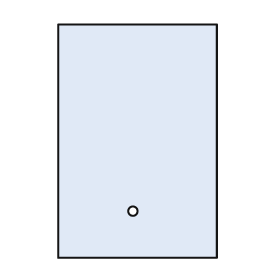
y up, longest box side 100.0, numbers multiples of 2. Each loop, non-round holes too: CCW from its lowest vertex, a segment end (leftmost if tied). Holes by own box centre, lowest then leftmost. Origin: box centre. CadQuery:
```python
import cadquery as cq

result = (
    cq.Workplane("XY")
    .moveTo(-34.0, -50.0)
    .lineTo(34.0, -50.0)
    .lineTo(34.0, 50.0)
    .lineTo(-34.0, 50.0)
    .close()
    .moveTo(-2.0, -30.0)
    .circle(2.0)
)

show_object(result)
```